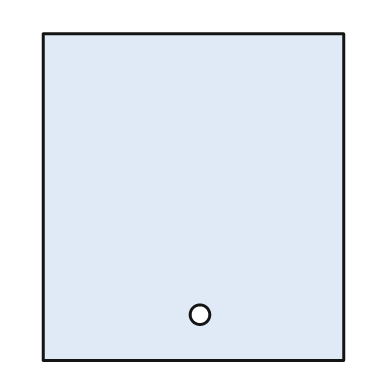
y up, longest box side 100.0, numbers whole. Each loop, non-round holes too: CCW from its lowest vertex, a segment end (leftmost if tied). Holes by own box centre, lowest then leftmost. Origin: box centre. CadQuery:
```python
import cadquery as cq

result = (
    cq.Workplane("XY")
    .moveTo(-46.0, -50.0)
    .lineTo(46.0, -50.0)
    .lineTo(46.0, 50.0)
    .lineTo(-46.0, 50.0)
    .close()
    .moveTo(2.0, -36.0)
    .circle(3.0)
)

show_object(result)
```